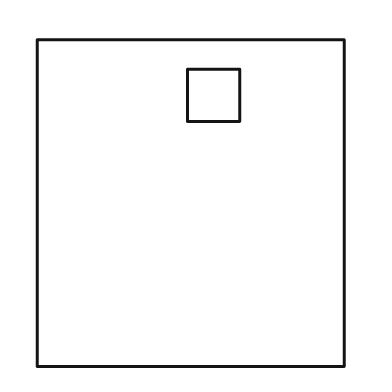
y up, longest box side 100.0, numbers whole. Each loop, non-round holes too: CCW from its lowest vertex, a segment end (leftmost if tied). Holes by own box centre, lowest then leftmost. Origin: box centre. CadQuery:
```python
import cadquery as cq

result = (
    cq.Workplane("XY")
    .moveTo(-47.0, -50.0)
    .lineTo(47.0, -50.0)
    .lineTo(47.0, 50.0)
    .lineTo(-47.0, 50.0)
    .close()
    .moveTo(-1.0, 25.0)
    .lineTo(15.0, 25.0)
    .lineTo(15.0, 41.0)
    .lineTo(-1.0, 41.0)
    .close()
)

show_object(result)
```